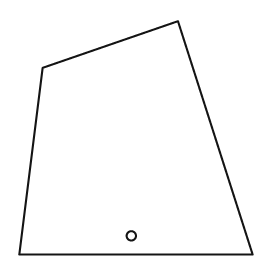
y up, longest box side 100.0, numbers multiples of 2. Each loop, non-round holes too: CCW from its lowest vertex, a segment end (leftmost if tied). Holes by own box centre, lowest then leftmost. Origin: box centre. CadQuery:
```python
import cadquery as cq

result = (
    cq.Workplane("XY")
    .moveTo(-50.0, -50.0)
    .lineTo(50.0, -50.0)
    .lineTo(18.0, 50.0)
    .lineTo(-40.0, 30.0)
    .close()
    .moveTo(-2.0, -42.0)
    .circle(2.0)
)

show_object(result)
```